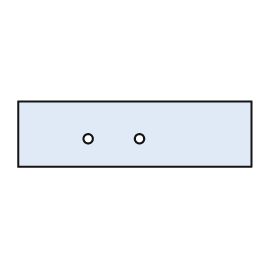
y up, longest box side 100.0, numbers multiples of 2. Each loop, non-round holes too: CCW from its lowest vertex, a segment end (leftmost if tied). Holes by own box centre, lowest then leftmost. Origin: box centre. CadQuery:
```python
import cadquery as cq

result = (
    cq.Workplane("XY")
    .moveTo(-50.0, -14.0)
    .lineTo(50.0, -14.0)
    .lineTo(50.0, 14.0)
    .lineTo(-50.0, 14.0)
    .close()
    .moveTo(-20.0, -2.0)
    .circle(2.0)
    .moveTo(2.0, -2.0)
    .circle(2.0)
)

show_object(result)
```